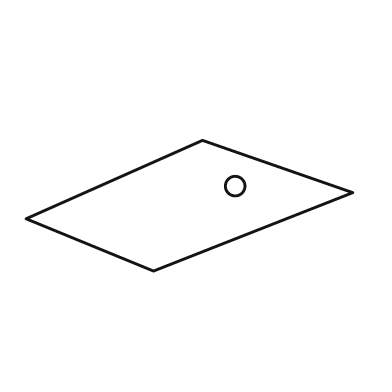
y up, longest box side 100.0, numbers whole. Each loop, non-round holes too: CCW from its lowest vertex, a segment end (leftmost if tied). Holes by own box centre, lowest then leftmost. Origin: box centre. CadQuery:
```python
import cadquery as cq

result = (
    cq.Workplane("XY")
    .moveTo(-11.0, -20.0)
    .lineTo(50.0, 4.0)
    .lineTo(4.0, 20.0)
    .lineTo(-50.0, -4.0)
    .close()
    .moveTo(14.0, 6.0)
    .circle(3.0)
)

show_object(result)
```